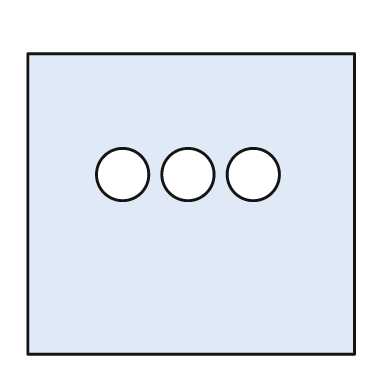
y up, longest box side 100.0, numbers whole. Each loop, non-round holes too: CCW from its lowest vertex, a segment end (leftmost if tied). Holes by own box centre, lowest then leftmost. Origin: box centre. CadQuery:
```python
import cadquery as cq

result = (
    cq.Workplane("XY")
    .moveTo(-50.0, -46.0)
    .lineTo(50.0, -46.0)
    .lineTo(50.0, 46.0)
    .lineTo(-50.0, 46.0)
    .close()
    .moveTo(-21.0, 9.0)
    .circle(8.0)
    .moveTo(-1.0, 9.0)
    .circle(8.0)
    .moveTo(19.0, 9.0)
    .circle(8.0)
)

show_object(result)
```